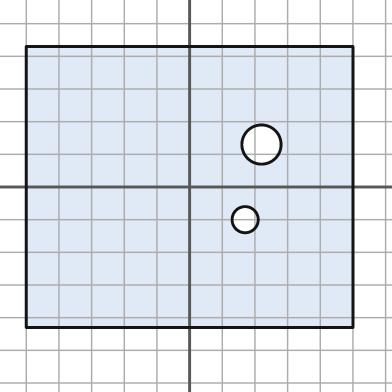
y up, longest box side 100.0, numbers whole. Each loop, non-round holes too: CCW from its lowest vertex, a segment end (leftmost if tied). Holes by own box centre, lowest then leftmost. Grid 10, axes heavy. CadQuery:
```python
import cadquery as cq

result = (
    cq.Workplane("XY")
    .moveTo(-50.0, -43.0)
    .lineTo(50.0, -43.0)
    .lineTo(50.0, 43.0)
    .lineTo(-50.0, 43.0)
    .close()
    .moveTo(17.0, -10.0)
    .circle(4.0)
    .moveTo(22.0, 13.0)
    .circle(6.0)
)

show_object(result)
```